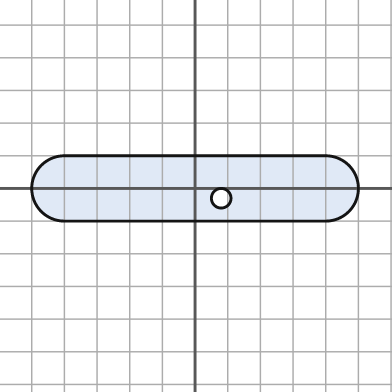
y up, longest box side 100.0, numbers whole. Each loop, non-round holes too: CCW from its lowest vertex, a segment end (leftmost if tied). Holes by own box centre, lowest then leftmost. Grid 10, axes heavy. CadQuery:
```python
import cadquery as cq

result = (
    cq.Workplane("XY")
    .moveTo(-40.0, -10.0)
    .lineTo(40.0, -10.0)
    .threePointArc((50.0, 0.0), (40.0, 10.0))
    .lineTo(-40.0, 10.0)
    .threePointArc((-50.0, 0.0), (-40.0, -10.0))
    .close()
    .moveTo(8.0, -3.0)
    .circle(3.0)
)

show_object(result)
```